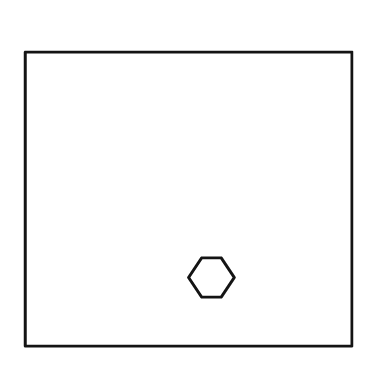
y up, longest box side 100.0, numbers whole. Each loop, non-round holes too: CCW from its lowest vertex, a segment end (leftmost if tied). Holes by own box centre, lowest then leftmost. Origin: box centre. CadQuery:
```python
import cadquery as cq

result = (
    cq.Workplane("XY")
    .moveTo(-50.0, -45.0)
    .lineTo(50.0, -45.0)
    .lineTo(50.0, 45.0)
    .lineTo(-50.0, 45.0)
    .close()
    .moveTo(4.0, -30.0)
    .lineTo(10.0, -30.0)
    .lineTo(14.0, -24.0)
    .lineTo(10.0, -18.0)
    .lineTo(4.0, -18.0)
    .lineTo(0.0, -24.0)
    .close()
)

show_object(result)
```